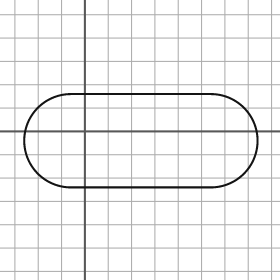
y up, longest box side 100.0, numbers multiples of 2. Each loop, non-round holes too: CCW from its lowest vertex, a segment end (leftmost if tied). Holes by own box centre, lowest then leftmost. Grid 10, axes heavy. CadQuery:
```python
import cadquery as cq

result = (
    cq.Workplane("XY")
    .moveTo(-6.0, -24.0)
    .lineTo(54.0, -24.0)
    .threePointArc((74.0, -4.0), (54.0, 16.0))
    .lineTo(-6.0, 16.0)
    .threePointArc((-26.0, -4.0), (-6.0, -24.0))
    .close()
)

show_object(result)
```